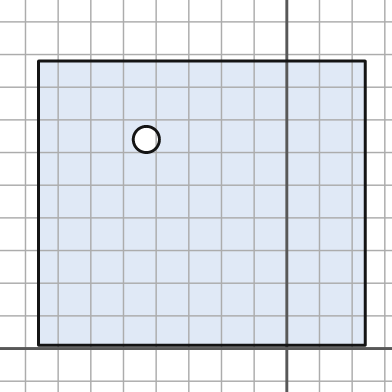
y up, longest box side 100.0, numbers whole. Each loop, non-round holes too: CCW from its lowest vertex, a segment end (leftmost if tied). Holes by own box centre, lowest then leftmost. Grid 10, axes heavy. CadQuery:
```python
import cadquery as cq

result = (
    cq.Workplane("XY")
    .moveTo(-76.0, 1.0)
    .lineTo(24.0, 1.0)
    .lineTo(24.0, 88.0)
    .lineTo(-76.0, 88.0)
    .close()
    .moveTo(-43.0, 64.0)
    .circle(4.0)
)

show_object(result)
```